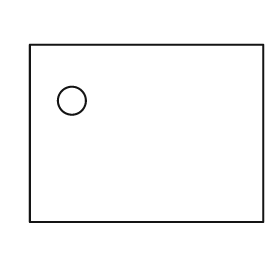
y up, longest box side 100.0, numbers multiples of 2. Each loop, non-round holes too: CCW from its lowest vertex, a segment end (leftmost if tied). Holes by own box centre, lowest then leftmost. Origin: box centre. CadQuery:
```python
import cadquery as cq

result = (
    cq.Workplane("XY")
    .moveTo(-50.0, -38.0)
    .lineTo(50.0, -38.0)
    .lineTo(50.0, 38.0)
    .lineTo(-50.0, 38.0)
    .close()
    .moveTo(-32.0, 14.0)
    .circle(6.0)
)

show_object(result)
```